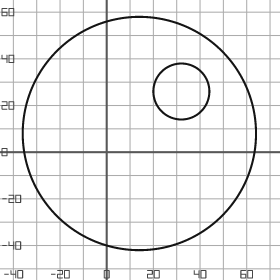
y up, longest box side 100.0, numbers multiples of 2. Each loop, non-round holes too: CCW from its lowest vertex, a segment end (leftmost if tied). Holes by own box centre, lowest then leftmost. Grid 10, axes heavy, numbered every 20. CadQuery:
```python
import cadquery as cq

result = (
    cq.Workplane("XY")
    .moveTo(14.0, 8.0)
    .circle(50.0)
    .moveTo(32.0, 26.0)
    .circle(12.0)
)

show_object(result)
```